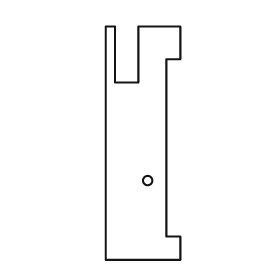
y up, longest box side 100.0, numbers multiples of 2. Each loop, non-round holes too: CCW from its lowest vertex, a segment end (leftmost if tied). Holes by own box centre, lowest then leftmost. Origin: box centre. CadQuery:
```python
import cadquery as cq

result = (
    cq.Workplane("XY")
    .moveTo(-16.0, -50.0)
    .lineTo(16.0, -50.0)
    .lineTo(16.0, -40.0)
    .lineTo(10.0, -40.0)
    .lineTo(10.0, 36.0)
    .lineTo(16.0, 36.0)
    .lineTo(16.0, 50.0)
    .lineTo(-2.0, 50.0)
    .lineTo(-2.0, 26.0)
    .lineTo(-12.0, 26.0)
    .lineTo(-12.0, 50.0)
    .lineTo(-16.0, 50.0)
    .close()
    .moveTo(2.0, -16.0)
    .circle(2.0)
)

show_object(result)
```